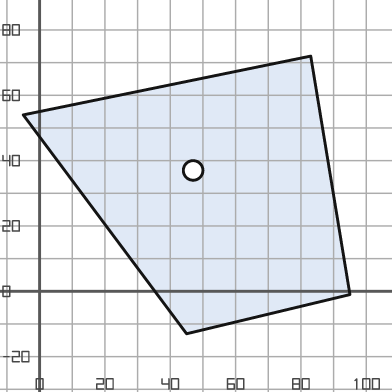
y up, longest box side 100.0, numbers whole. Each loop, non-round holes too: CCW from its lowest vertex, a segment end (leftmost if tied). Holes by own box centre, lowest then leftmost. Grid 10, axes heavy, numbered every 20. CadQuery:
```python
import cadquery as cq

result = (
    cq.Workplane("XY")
    .moveTo(45.0, -13.0)
    .lineTo(95.0, -1.0)
    .lineTo(83.0, 72.0)
    .lineTo(-5.0, 54.0)
    .close()
    .moveTo(47.0, 37.0)
    .circle(3.0)
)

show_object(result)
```